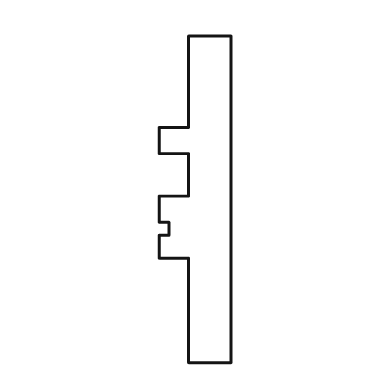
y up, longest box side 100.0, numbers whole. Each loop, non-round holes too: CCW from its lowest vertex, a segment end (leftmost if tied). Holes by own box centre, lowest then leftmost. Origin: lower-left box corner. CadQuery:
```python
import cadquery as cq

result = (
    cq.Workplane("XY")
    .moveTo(9.0, 0.0)
    .lineTo(22.0, 0.0)
    .lineTo(22.0, 100.0)
    .lineTo(9.0, 100.0)
    .lineTo(9.0, 72.0)
    .lineTo(0.0, 72.0)
    .lineTo(0.0, 64.0)
    .lineTo(9.0, 64.0)
    .lineTo(9.0, 51.0)
    .lineTo(0.0, 51.0)
    .lineTo(0.0, 43.0)
    .lineTo(3.0, 43.0)
    .lineTo(3.0, 39.0)
    .lineTo(0.0, 39.0)
    .lineTo(0.0, 32.0)
    .lineTo(9.0, 32.0)
    .close()
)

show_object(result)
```